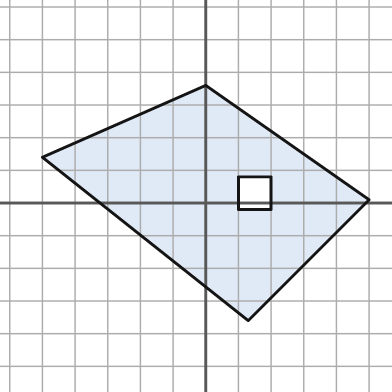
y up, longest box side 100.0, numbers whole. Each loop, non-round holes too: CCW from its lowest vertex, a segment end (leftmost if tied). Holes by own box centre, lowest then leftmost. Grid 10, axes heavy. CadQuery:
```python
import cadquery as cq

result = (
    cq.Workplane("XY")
    .moveTo(13.0, -36.0)
    .lineTo(50.0, 1.0)
    .lineTo(0.0, 36.0)
    .lineTo(-50.0, 14.0)
    .close()
    .moveTo(10.0, -2.0)
    .lineTo(20.0, -2.0)
    .lineTo(20.0, 8.0)
    .lineTo(10.0, 8.0)
    .close()
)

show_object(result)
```